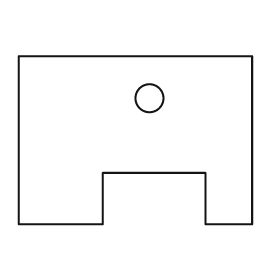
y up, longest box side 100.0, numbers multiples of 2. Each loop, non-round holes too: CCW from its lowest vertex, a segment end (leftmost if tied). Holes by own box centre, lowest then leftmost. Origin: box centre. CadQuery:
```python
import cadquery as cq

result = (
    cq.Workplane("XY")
    .moveTo(-50.0, -36.0)
    .lineTo(-14.0, -36.0)
    .lineTo(-14.0, -14.0)
    .lineTo(30.0, -14.0)
    .lineTo(30.0, -36.0)
    .lineTo(50.0, -36.0)
    .lineTo(50.0, 36.0)
    .lineTo(-50.0, 36.0)
    .close()
    .moveTo(6.0, 18.0)
    .circle(6.0)
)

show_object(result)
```